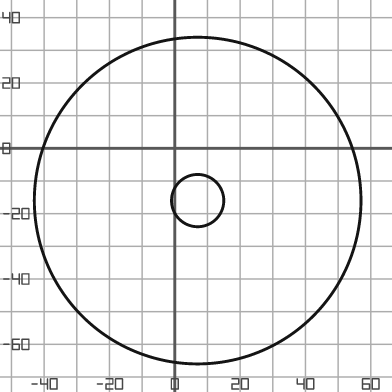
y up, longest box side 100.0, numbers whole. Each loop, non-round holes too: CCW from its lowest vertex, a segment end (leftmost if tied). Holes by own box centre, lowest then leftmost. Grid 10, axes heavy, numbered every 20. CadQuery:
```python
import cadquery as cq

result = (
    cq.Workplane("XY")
    .moveTo(7.0, -16.0)
    .circle(50.0)
    .moveTo(7.0, -16.0)
    .circle(8.0)
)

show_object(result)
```